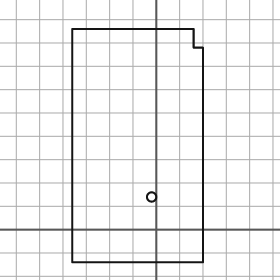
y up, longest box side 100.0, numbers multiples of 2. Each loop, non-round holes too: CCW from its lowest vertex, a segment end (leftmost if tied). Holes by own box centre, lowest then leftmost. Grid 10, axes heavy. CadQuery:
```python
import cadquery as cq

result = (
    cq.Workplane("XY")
    .moveTo(-36.0, -14.0)
    .lineTo(20.0, -14.0)
    .lineTo(20.0, 78.0)
    .lineTo(16.0, 78.0)
    .lineTo(16.0, 86.0)
    .lineTo(-36.0, 86.0)
    .close()
    .moveTo(-2.0, 14.0)
    .circle(2.0)
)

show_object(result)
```